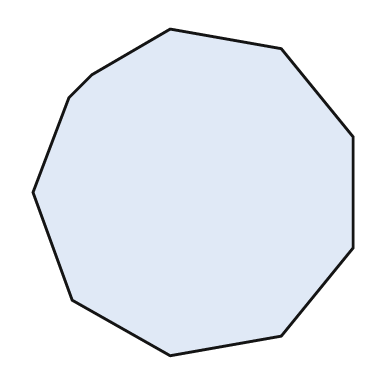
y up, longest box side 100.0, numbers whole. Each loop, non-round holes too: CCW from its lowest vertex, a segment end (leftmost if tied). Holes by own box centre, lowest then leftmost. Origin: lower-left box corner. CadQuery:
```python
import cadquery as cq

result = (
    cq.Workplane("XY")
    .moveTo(42.0, 0.0)
    .lineTo(76.0, 6.0)
    .lineTo(98.0, 33.0)
    .lineTo(98.0, 67.0)
    .lineTo(76.0, 94.0)
    .lineTo(42.0, 100.0)
    .lineTo(18.0, 86.0)
    .lineTo(11.0, 79.0)
    .lineTo(0.0, 50.0)
    .lineTo(12.0, 17.0)
    .close()
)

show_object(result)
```